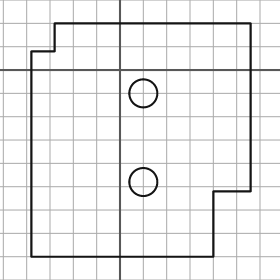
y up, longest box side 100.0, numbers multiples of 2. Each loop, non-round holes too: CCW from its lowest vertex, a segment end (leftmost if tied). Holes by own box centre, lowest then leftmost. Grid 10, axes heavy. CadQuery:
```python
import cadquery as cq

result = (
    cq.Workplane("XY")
    .moveTo(-38.0, -80.0)
    .lineTo(40.0, -80.0)
    .lineTo(40.0, -52.0)
    .lineTo(56.0, -52.0)
    .lineTo(56.0, 20.0)
    .lineTo(-28.0, 20.0)
    .lineTo(-28.0, 8.0)
    .lineTo(-38.0, 8.0)
    .close()
    .moveTo(10.0, -48.0)
    .circle(6.0)
    .moveTo(10.0, -10.0)
    .circle(6.0)
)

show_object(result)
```